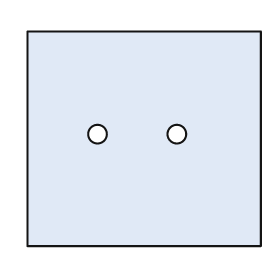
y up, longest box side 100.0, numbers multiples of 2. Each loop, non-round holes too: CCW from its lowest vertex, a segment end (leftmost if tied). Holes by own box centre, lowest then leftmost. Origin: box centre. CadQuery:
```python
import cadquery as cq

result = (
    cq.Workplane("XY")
    .moveTo(-50.0, -46.0)
    .lineTo(50.0, -46.0)
    .lineTo(50.0, 46.0)
    .lineTo(-50.0, 46.0)
    .close()
    .moveTo(-20.0, 2.0)
    .circle(4.0)
    .moveTo(14.0, 2.0)
    .circle(4.0)
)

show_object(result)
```